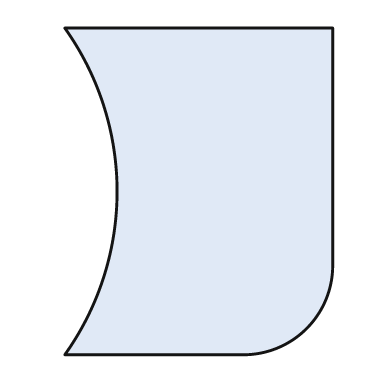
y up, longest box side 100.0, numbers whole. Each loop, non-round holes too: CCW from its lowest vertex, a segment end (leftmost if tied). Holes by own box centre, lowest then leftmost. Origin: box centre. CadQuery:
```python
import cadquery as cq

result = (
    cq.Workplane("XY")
    .moveTo(-41.0, -50.0)
    .lineTo(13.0, -50.0)
    .threePointArc((33.0, -42.0), (41.0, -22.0))
    .lineTo(41.0, 50.0)
    .lineTo(-41.0, 50.0)
    .threePointArc((-25.0, 0.0), (-41.0, -50.0))
    .close()
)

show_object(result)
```